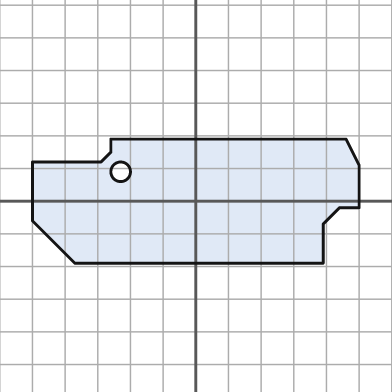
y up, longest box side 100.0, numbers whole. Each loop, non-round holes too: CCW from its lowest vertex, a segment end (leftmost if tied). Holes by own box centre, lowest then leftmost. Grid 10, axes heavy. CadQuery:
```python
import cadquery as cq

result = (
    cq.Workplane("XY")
    .moveTo(-37.0, -19.0)
    .lineTo(39.0, -19.0)
    .lineTo(39.0, -7.0)
    .lineTo(44.0, -2.0)
    .lineTo(50.0, -2.0)
    .lineTo(50.0, 11.0)
    .lineTo(46.0, 19.0)
    .lineTo(-26.0, 19.0)
    .lineTo(-26.0, 15.0)
    .lineTo(-29.0, 12.0)
    .lineTo(-50.0, 12.0)
    .lineTo(-50.0, -6.0)
    .close()
    .moveTo(-23.0, 9.0)
    .circle(3.0)
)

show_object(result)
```